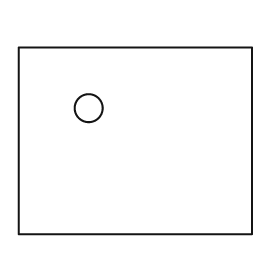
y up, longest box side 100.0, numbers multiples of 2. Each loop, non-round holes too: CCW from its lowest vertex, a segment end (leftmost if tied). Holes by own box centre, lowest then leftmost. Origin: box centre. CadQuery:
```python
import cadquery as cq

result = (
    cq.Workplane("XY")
    .moveTo(-50.0, -40.0)
    .lineTo(50.0, -40.0)
    .lineTo(50.0, 40.0)
    .lineTo(-50.0, 40.0)
    .close()
    .moveTo(-20.0, 14.0)
    .circle(6.0)
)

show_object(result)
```